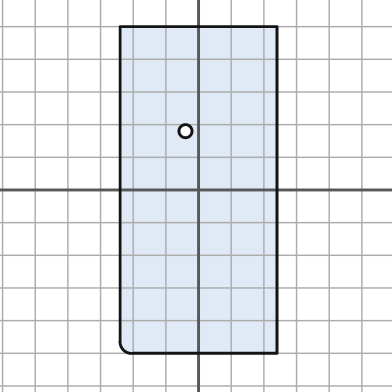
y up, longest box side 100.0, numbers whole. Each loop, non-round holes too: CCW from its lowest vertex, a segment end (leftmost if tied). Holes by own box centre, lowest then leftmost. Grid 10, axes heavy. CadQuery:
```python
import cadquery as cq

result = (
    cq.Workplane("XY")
    .moveTo(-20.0, -50.0)
    .lineTo(24.0, -50.0)
    .lineTo(24.0, 50.0)
    .lineTo(-24.0, 50.0)
    .lineTo(-24.0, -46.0)
    .threePointArc((-23.0, -49.0), (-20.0, -50.0))
    .close()
    .moveTo(-4.0, 18.0)
    .circle(2.0)
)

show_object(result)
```